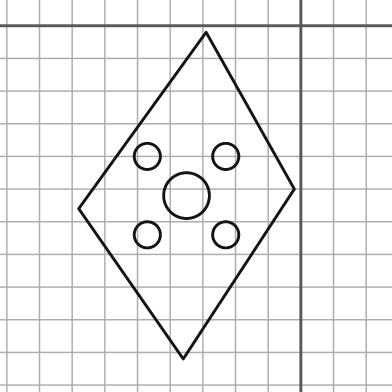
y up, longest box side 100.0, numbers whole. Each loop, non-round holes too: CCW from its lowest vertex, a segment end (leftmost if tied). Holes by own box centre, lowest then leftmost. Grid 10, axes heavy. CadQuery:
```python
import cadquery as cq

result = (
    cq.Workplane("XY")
    .moveTo(-36.0, -102.0)
    .lineTo(-2.0, -50.0)
    .lineTo(-29.0, -2.0)
    .lineTo(-68.0, -56.0)
    .close()
    .moveTo(-47.0, -64.0)
    .circle(4.0)
    .moveTo(-23.0, -64.0)
    .circle(4.0)
    .moveTo(-35.0, -52.0)
    .circle(7.0)
    .moveTo(-47.0, -40.0)
    .circle(4.0)
    .moveTo(-23.0, -40.0)
    .circle(4.0)
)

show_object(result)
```